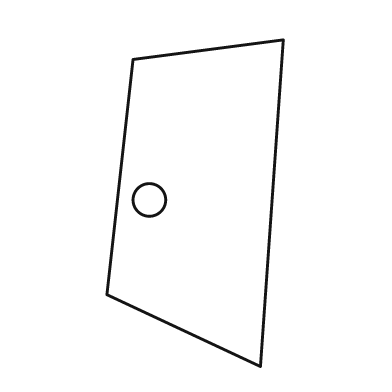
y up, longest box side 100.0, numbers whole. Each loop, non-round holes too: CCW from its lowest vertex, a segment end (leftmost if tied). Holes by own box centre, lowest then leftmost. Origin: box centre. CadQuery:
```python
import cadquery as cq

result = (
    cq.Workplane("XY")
    .moveTo(20.0, -50.0)
    .lineTo(27.0, 50.0)
    .lineTo(-19.0, 44.0)
    .lineTo(-27.0, -28.0)
    .close()
    .moveTo(-14.0, 1.0)
    .circle(5.0)
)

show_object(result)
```